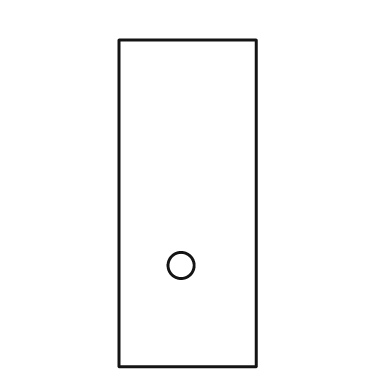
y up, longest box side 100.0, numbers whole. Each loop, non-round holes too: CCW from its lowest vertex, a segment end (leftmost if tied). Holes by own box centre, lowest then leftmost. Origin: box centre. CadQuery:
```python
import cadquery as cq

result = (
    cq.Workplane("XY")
    .moveTo(-21.0, -50.0)
    .lineTo(21.0, -50.0)
    .lineTo(21.0, 50.0)
    .lineTo(-21.0, 50.0)
    .close()
    .moveTo(-2.0, -19.0)
    .circle(4.0)
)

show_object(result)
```